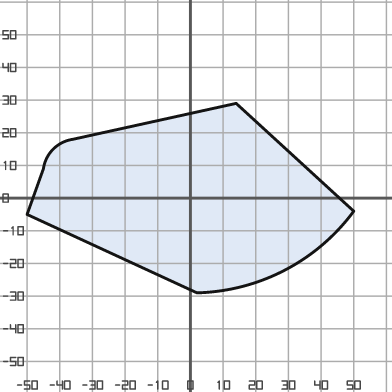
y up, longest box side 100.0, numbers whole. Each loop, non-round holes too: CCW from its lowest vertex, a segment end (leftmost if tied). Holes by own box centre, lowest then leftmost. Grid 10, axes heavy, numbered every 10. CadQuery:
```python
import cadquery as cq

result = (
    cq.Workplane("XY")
    .moveTo(2.0, -29.0)
    .threePointArc((29.0, -22.0), (50.0, -4.0))
    .lineTo(14.0, 29.0)
    .lineTo(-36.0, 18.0)
    .threePointArc((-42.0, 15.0), (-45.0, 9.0))
    .lineTo(-50.0, -5.0)
    .close()
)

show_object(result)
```